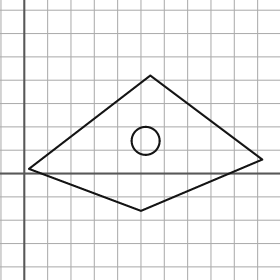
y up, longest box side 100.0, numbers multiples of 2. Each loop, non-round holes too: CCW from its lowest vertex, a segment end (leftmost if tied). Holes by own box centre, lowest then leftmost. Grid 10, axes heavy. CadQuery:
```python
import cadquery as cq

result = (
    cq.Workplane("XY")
    .moveTo(50.0, -16.0)
    .lineTo(102.0, 6.0)
    .lineTo(54.0, 42.0)
    .lineTo(2.0, 2.0)
    .close()
    .moveTo(52.0, 14.0)
    .circle(6.0)
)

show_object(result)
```